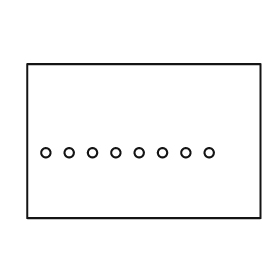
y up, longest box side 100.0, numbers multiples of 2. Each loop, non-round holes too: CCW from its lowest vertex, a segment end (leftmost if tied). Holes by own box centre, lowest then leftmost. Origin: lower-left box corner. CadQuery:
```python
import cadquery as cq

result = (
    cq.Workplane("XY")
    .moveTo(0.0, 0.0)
    .lineTo(100.0, 0.0)
    .lineTo(100.0, 66.0)
    .lineTo(0.0, 66.0)
    .close()
    .moveTo(8.0, 28.0)
    .circle(2.0)
    .moveTo(18.0, 28.0)
    .circle(2.0)
    .moveTo(28.0, 28.0)
    .circle(2.0)
    .moveTo(38.0, 28.0)
    .circle(2.0)
    .moveTo(48.0, 28.0)
    .circle(2.0)
    .moveTo(58.0, 28.0)
    .circle(2.0)
    .moveTo(68.0, 28.0)
    .circle(2.0)
    .moveTo(78.0, 28.0)
    .circle(2.0)
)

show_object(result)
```